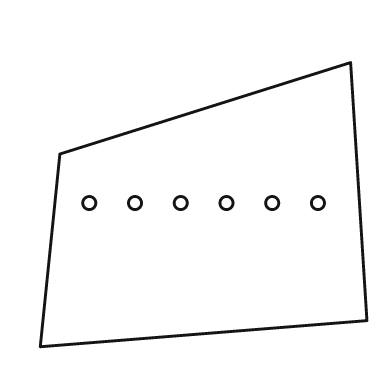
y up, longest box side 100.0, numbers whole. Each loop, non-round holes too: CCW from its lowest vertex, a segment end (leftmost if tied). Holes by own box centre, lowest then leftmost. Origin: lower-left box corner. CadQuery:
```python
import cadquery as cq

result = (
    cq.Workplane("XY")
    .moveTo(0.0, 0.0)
    .lineTo(100.0, 8.0)
    .lineTo(95.0, 87.0)
    .lineTo(6.0, 59.0)
    .close()
    .moveTo(15.0, 44.0)
    .circle(2.0)
    .moveTo(29.0, 44.0)
    .circle(2.0)
    .moveTo(43.0, 44.0)
    .circle(2.0)
    .moveTo(57.0, 44.0)
    .circle(2.0)
    .moveTo(71.0, 44.0)
    .circle(2.0)
    .moveTo(85.0, 44.0)
    .circle(2.0)
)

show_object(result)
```